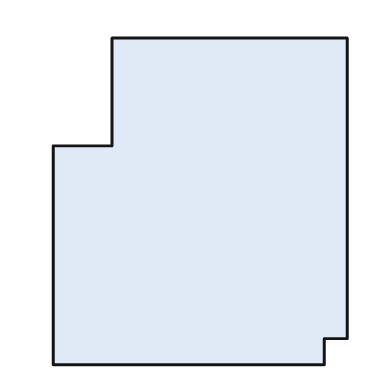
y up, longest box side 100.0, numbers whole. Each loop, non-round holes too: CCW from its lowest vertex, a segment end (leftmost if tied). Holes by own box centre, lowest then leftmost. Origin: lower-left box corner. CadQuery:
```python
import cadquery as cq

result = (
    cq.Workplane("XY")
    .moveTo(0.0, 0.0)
    .lineTo(83.0, 0.0)
    .lineTo(83.0, 8.0)
    .lineTo(90.0, 8.0)
    .lineTo(90.0, 100.0)
    .lineTo(18.0, 100.0)
    .lineTo(18.0, 67.0)
    .lineTo(0.0, 67.0)
    .close()
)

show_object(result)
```